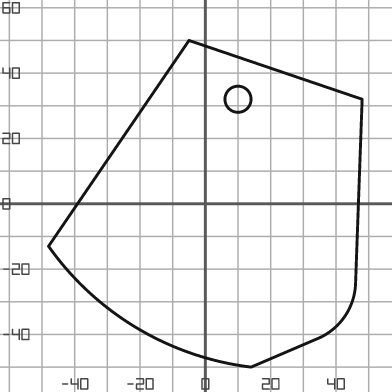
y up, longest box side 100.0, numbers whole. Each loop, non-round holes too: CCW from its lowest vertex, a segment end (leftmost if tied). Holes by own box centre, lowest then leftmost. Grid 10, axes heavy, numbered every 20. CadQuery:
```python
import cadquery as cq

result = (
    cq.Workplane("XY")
    .moveTo(14.0, -50.0)
    .lineTo(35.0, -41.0)
    .threePointArc((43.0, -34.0), (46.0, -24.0))
    .lineTo(48.0, 32.0)
    .lineTo(-5.0, 50.0)
    .lineTo(-48.0, -13.0)
    .threePointArc((-21.0, -38.0), (14.0, -50.0))
    .close()
    .moveTo(10.0, 32.0)
    .circle(4.0)
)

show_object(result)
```